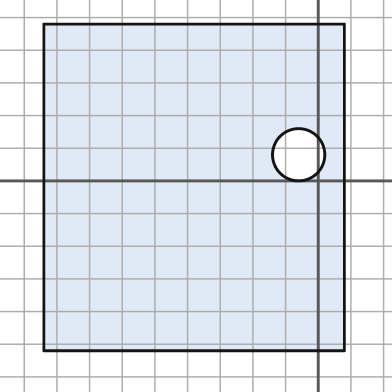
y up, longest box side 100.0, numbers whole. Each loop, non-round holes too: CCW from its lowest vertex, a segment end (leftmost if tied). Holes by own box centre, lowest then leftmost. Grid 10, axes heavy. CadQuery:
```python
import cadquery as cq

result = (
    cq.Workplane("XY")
    .moveTo(-84.0, -52.0)
    .lineTo(8.0, -52.0)
    .lineTo(8.0, 48.0)
    .lineTo(-84.0, 48.0)
    .close()
    .moveTo(-6.0, 8.0)
    .circle(8.0)
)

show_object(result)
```